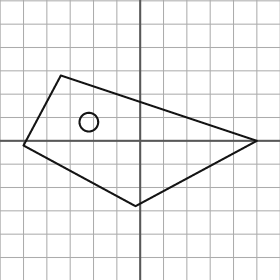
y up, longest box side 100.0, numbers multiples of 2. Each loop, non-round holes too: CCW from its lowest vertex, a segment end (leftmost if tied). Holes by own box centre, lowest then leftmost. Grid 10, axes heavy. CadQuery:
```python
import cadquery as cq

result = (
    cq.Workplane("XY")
    .moveTo(-2.0, -28.0)
    .lineTo(50.0, 0.0)
    .lineTo(-34.0, 28.0)
    .lineTo(-50.0, -2.0)
    .close()
    .moveTo(-22.0, 8.0)
    .circle(4.0)
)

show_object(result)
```